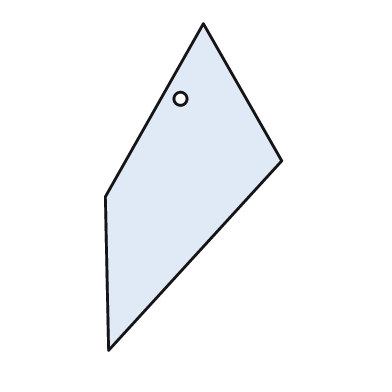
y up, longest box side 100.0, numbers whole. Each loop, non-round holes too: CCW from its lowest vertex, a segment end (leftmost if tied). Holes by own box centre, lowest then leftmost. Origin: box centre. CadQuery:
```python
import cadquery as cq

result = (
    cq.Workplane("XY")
    .moveTo(-26.0, -50.0)
    .lineTo(27.0, 8.0)
    .lineTo(3.0, 50.0)
    .lineTo(-27.0, -3.0)
    .close()
    .moveTo(-4.0, 27.0)
    .circle(2.0)
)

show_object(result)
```